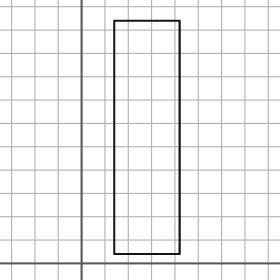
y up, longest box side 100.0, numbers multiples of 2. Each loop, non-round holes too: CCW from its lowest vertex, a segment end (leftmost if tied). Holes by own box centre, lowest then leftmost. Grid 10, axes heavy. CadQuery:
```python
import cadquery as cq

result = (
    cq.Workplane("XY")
    .moveTo(14.0, 4.0)
    .lineTo(42.0, 4.0)
    .lineTo(42.0, 104.0)
    .lineTo(14.0, 104.0)
    .close()
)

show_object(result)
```